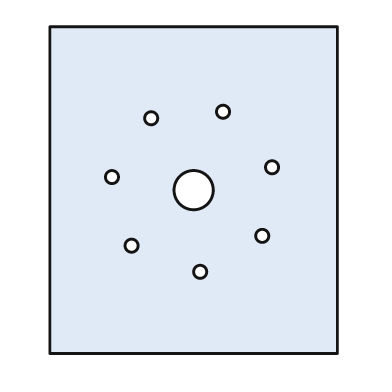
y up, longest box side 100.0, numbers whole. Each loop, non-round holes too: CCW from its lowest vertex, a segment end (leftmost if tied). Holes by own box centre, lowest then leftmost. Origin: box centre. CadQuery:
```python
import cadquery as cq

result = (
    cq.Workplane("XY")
    .moveTo(-44.0, -50.0)
    .lineTo(44.0, -50.0)
    .lineTo(44.0, 50.0)
    .lineTo(-44.0, 50.0)
    .close()
    .moveTo(2.0, -25.0)
    .circle(2.0)
    .moveTo(-19.0, -17.0)
    .circle(2.0)
    .moveTo(21.0, -14.0)
    .circle(2.0)
    .moveTo(0.0, 0.0)
    .circle(6.0)
    .moveTo(-25.0, 4.0)
    .circle(2.0)
    .moveTo(24.0, 7.0)
    .circle(2.0)
    .moveTo(-13.0, 22.0)
    .circle(2.0)
    .moveTo(9.0, 24.0)
    .circle(2.0)
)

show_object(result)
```